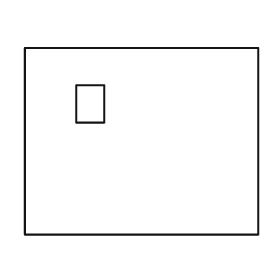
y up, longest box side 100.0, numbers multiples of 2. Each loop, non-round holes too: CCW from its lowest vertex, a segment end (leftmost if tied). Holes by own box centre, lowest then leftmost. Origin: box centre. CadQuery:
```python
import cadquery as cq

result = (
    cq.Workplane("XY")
    .moveTo(-50.0, -40.0)
    .lineTo(50.0, -40.0)
    .lineTo(50.0, 40.0)
    .lineTo(-50.0, 40.0)
    .close()
    .moveTo(-28.0, 8.0)
    .lineTo(-16.0, 8.0)
    .lineTo(-16.0, 24.0)
    .lineTo(-28.0, 24.0)
    .close()
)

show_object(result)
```